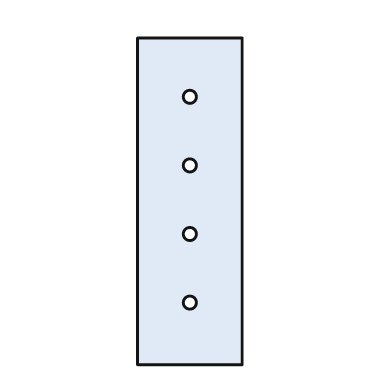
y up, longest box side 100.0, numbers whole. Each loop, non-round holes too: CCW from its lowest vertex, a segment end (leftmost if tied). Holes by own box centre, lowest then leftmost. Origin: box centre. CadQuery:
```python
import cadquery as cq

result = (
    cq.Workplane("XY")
    .moveTo(-16.0, -50.0)
    .lineTo(16.0, -50.0)
    .lineTo(16.0, 50.0)
    .lineTo(-16.0, 50.0)
    .close()
    .moveTo(0.0, -31.0)
    .circle(2.0)
    .moveTo(0.0, -10.0)
    .circle(2.0)
    .moveTo(0.0, 11.0)
    .circle(2.0)
    .moveTo(0.0, 32.0)
    .circle(2.0)
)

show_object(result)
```